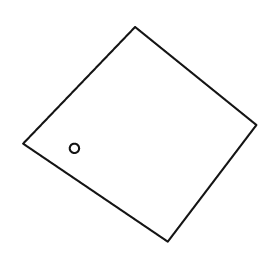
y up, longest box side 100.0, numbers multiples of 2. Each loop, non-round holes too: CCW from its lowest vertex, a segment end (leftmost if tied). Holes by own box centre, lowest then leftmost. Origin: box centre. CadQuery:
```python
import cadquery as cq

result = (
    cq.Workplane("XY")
    .moveTo(12.0, -46.0)
    .lineTo(50.0, 4.0)
    .lineTo(-2.0, 46.0)
    .lineTo(-50.0, -4.0)
    .close()
    .moveTo(-28.0, -6.0)
    .circle(2.0)
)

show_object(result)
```